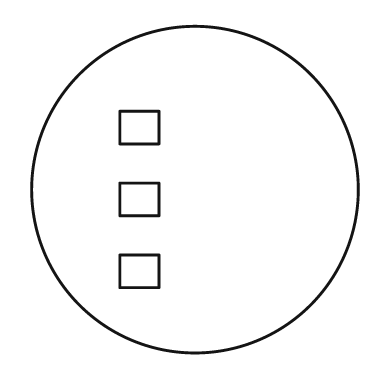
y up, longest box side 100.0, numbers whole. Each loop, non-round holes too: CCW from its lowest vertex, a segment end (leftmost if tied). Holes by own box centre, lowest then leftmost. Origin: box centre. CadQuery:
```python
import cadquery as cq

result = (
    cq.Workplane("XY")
    .moveTo(0.0, 0.0)
    .circle(50.0)
    .moveTo(-23.0, -30.0)
    .lineTo(-11.0, -30.0)
    .lineTo(-11.0, -20.0)
    .lineTo(-23.0, -20.0)
    .close()
    .moveTo(-23.0, -8.0)
    .lineTo(-11.0, -8.0)
    .lineTo(-11.0, 2.0)
    .lineTo(-23.0, 2.0)
    .close()
    .moveTo(-23.0, 14.0)
    .lineTo(-11.0, 14.0)
    .lineTo(-11.0, 24.0)
    .lineTo(-23.0, 24.0)
    .close()
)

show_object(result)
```